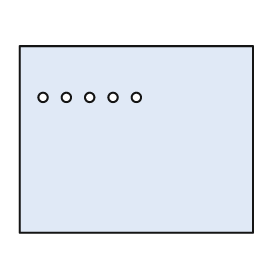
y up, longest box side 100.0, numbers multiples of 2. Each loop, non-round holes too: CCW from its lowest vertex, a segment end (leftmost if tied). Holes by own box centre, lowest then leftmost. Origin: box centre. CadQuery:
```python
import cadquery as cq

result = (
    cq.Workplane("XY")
    .moveTo(-50.0, -40.0)
    .lineTo(50.0, -40.0)
    .lineTo(50.0, 40.0)
    .lineTo(-50.0, 40.0)
    .close()
    .moveTo(-40.0, 18.0)
    .circle(2.0)
    .moveTo(-30.0, 18.0)
    .circle(2.0)
    .moveTo(-20.0, 18.0)
    .circle(2.0)
    .moveTo(-10.0, 18.0)
    .circle(2.0)
    .moveTo(0.0, 18.0)
    .circle(2.0)
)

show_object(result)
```